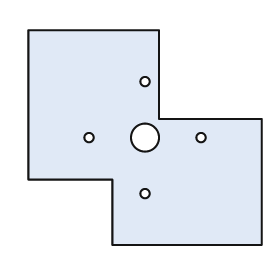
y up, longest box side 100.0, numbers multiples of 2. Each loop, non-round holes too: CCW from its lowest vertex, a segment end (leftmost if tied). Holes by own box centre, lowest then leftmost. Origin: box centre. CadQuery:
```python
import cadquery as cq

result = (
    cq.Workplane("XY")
    .moveTo(-14.0, -46.0)
    .lineTo(50.0, -46.0)
    .lineTo(50.0, 8.0)
    .lineTo(6.0, 8.0)
    .lineTo(6.0, 46.0)
    .lineTo(-50.0, 46.0)
    .lineTo(-50.0, -18.0)
    .lineTo(-14.0, -18.0)
    .close()
    .moveTo(0.0, -24.0)
    .circle(2.0)
    .moveTo(-24.0, 0.0)
    .circle(2.0)
    .moveTo(0.0, 0.0)
    .circle(6.0)
    .moveTo(24.0, 0.0)
    .circle(2.0)
    .moveTo(0.0, 24.0)
    .circle(2.0)
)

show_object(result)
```